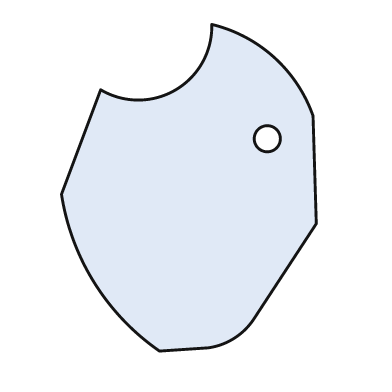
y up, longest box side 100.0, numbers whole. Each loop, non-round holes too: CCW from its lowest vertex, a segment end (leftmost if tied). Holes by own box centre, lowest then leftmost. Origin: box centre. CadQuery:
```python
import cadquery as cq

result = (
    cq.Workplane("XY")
    .moveTo(-9.0, -50.0)
    .lineTo(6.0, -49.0)
    .threePointArc((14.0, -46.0), (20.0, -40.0))
    .lineTo(39.0, -11.0)
    .lineTo(38.0, 22.0)
    .threePointArc((26.0, 40.0), (7.0, 50.0))
    .threePointArc((-4.0, 30.0), (-27.0, 30.0))
    .lineTo(-39.0, -2.0)
    .threePointArc((-29.0, -29.0), (-9.0, -50.0))
    .close()
    .moveTo(24.0, 15.0)
    .circle(4.0)
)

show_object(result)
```